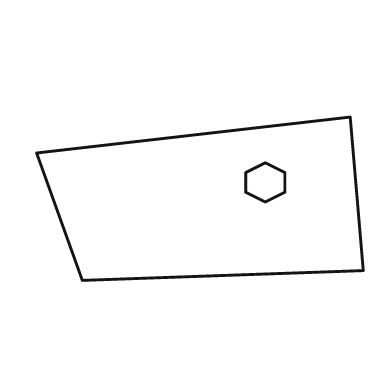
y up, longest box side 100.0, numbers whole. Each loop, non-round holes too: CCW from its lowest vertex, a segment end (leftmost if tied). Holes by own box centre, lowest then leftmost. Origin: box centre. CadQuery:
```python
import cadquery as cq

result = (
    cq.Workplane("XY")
    .moveTo(-36.0, -25.0)
    .lineTo(50.0, -22.0)
    .lineTo(46.0, 25.0)
    .lineTo(-50.0, 14.0)
    .close()
    .moveTo(20.0, -1.0)
    .lineTo(26.0, 2.0)
    .lineTo(26.0, 8.0)
    .lineTo(20.0, 11.0)
    .lineTo(14.0, 8.0)
    .lineTo(14.0, 2.0)
    .close()
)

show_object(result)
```